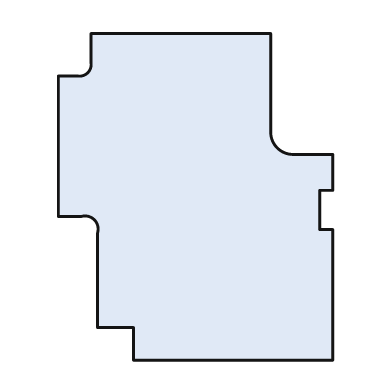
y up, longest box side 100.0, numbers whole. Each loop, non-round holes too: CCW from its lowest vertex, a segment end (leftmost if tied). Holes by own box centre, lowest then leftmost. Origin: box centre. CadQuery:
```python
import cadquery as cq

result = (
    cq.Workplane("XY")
    .moveTo(-19.0, -50.0)
    .lineTo(42.0, -50.0)
    .lineTo(42.0, -10.0)
    .lineTo(38.0, -10.0)
    .lineTo(38.0, 2.0)
    .lineTo(42.0, 2.0)
    .lineTo(42.0, 13.0)
    .lineTo(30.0, 13.0)
    .threePointArc((25.0, 15.0), (23.0, 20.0))
    .lineTo(23.0, 50.0)
    .lineTo(-32.0, 50.0)
    .lineTo(-32.0, 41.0)
    .threePointArc((-33.0, 38.0), (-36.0, 37.0))
    .lineTo(-42.0, 37.0)
    .lineTo(-42.0, -6.0)
    .lineTo(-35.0, -6.0)
    .threePointArc((-31.0, -7.0), (-30.0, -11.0))
    .lineTo(-30.0, -40.0)
    .lineTo(-19.0, -40.0)
    .close()
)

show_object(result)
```